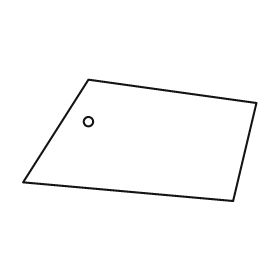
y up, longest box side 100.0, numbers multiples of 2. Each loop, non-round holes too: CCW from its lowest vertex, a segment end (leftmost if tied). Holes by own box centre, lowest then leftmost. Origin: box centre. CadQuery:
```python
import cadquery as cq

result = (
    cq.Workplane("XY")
    .moveTo(40.0, -26.0)
    .lineTo(50.0, 16.0)
    .lineTo(-22.0, 26.0)
    .lineTo(-50.0, -18.0)
    .close()
    .moveTo(-22.0, 8.0)
    .circle(2.0)
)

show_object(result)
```